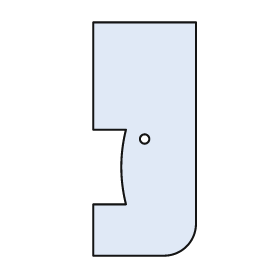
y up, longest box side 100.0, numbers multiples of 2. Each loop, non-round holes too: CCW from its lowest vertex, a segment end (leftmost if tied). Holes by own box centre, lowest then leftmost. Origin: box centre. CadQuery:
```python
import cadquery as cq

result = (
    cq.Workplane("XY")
    .moveTo(-22.0, -50.0)
    .lineTo(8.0, -50.0)
    .threePointArc((18.0, -46.0), (22.0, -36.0))
    .lineTo(22.0, 50.0)
    .lineTo(-22.0, 50.0)
    .lineTo(-22.0, 4.0)
    .lineTo(-8.0, 4.0)
    .threePointArc((-10.0, -12.0), (-8.0, -28.0))
    .lineTo(-22.0, -28.0)
    .close()
    .moveTo(0.0, 0.0)
    .circle(2.0)
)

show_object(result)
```